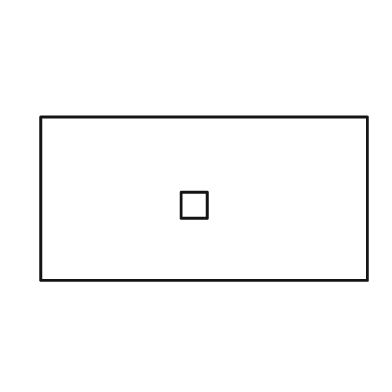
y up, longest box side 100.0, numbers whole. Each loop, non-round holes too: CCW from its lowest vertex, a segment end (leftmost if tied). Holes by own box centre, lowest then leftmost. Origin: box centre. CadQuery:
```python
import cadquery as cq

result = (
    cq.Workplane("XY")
    .moveTo(-50.0, -25.0)
    .lineTo(50.0, -25.0)
    .lineTo(50.0, 25.0)
    .lineTo(-50.0, 25.0)
    .close()
    .moveTo(-7.0, -6.0)
    .lineTo(1.0, -6.0)
    .lineTo(1.0, 2.0)
    .lineTo(-7.0, 2.0)
    .close()
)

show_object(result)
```